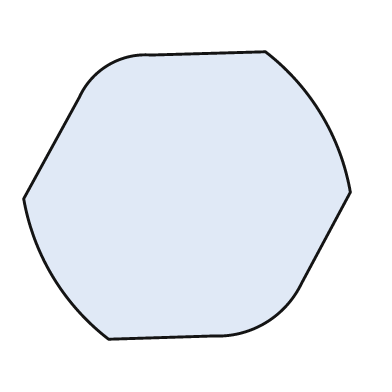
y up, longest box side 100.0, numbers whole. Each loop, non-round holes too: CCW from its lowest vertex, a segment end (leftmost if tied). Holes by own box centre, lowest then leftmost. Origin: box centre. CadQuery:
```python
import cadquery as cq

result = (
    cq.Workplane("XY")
    .moveTo(-24.0, -44.0)
    .lineTo(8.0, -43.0)
    .threePointArc((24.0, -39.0), (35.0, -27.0))
    .lineTo(50.0, 1.0)
    .threePointArc((41.0, 25.0), (24.0, 44.0))
    .lineTo(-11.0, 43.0)
    .threePointArc((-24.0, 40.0), (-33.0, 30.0))
    .lineTo(-50.0, -1.0)
    .threePointArc((-41.0, -25.0), (-24.0, -44.0))
    .close()
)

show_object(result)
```